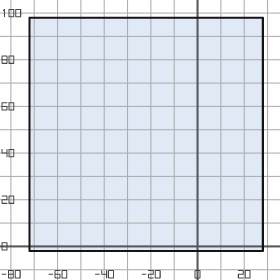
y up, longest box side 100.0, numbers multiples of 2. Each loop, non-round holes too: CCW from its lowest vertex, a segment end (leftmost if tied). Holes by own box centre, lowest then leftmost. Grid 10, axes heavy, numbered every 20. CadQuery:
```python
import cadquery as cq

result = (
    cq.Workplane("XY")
    .moveTo(-72.0, -2.0)
    .lineTo(28.0, -2.0)
    .lineTo(28.0, 98.0)
    .lineTo(-72.0, 98.0)
    .close()
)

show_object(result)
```